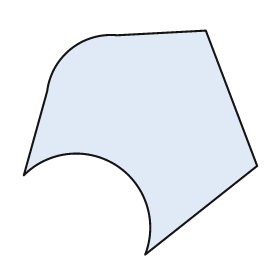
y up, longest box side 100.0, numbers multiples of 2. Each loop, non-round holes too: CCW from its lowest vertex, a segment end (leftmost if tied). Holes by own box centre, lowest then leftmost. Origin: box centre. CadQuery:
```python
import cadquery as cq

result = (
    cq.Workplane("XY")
    .moveTo(2.0, -48.0)
    .lineTo(50.0, -10.0)
    .lineTo(28.0, 48.0)
    .lineTo(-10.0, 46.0)
    .threePointArc((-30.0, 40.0), (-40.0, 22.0))
    .lineTo(-50.0, -14.0)
    .threePointArc((-10.0, -10.0), (2.0, -48.0))
    .close()
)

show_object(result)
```